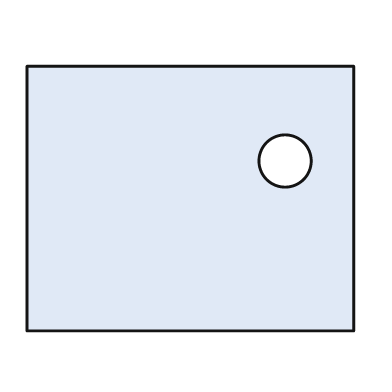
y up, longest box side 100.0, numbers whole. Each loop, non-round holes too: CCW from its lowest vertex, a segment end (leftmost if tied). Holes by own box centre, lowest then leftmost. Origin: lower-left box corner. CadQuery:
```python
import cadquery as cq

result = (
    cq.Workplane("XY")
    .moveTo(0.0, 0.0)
    .lineTo(100.0, 0.0)
    .lineTo(100.0, 81.0)
    .lineTo(0.0, 81.0)
    .close()
    .moveTo(79.0, 52.0)
    .circle(8.0)
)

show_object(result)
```